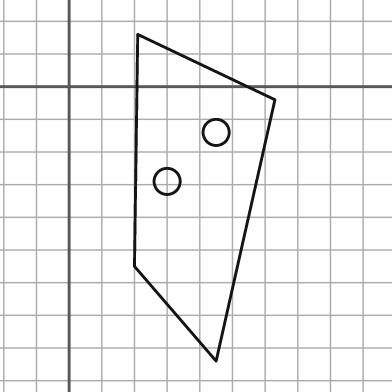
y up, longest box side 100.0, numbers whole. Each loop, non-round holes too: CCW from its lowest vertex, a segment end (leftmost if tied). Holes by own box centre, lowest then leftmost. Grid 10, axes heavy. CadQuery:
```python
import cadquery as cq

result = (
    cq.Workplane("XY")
    .moveTo(45.0, -84.0)
    .lineTo(63.0, -4.0)
    .lineTo(21.0, 16.0)
    .lineTo(20.0, -55.0)
    .close()
    .moveTo(30.0, -29.0)
    .circle(4.0)
    .moveTo(45.0, -14.0)
    .circle(4.0)
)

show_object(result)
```